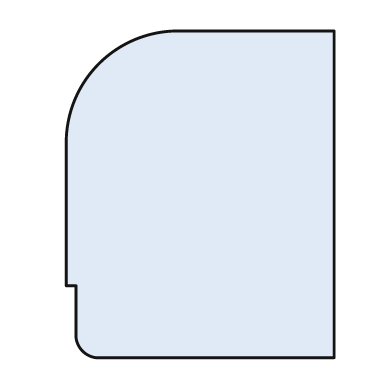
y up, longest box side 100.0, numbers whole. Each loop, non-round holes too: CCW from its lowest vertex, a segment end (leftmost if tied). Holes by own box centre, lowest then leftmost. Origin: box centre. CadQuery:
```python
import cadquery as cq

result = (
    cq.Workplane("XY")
    .moveTo(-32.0, -50.0)
    .lineTo(41.0, -50.0)
    .lineTo(41.0, 50.0)
    .lineTo(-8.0, 50.0)
    .threePointArc((-31.0, 40.0), (-41.0, 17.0))
    .lineTo(-41.0, -28.0)
    .lineTo(-38.0, -28.0)
    .lineTo(-38.0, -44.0)
    .threePointArc((-36.0, -48.0), (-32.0, -50.0))
    .close()
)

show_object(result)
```